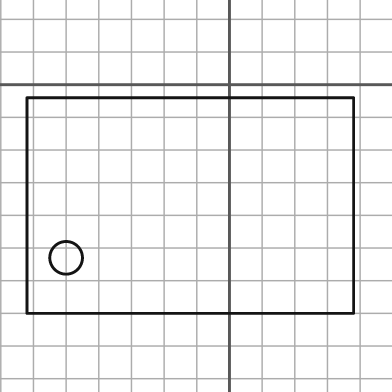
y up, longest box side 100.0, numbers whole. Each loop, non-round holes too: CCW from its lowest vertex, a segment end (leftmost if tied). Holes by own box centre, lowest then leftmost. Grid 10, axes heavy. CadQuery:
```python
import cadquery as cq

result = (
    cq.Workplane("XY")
    .moveTo(-62.0, -70.0)
    .lineTo(38.0, -70.0)
    .lineTo(38.0, -4.0)
    .lineTo(-62.0, -4.0)
    .close()
    .moveTo(-50.0, -53.0)
    .circle(5.0)
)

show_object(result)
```